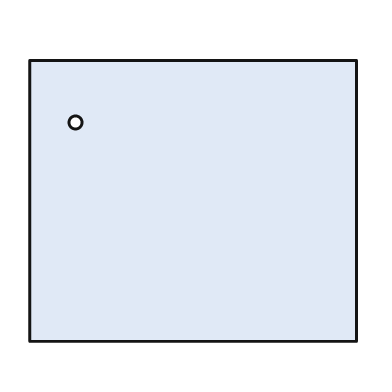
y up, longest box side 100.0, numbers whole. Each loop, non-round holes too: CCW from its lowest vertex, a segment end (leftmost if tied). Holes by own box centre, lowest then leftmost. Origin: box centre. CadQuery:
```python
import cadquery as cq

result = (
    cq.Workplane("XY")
    .moveTo(-50.0, -43.0)
    .lineTo(50.0, -43.0)
    .lineTo(50.0, 43.0)
    .lineTo(-50.0, 43.0)
    .close()
    .moveTo(-36.0, 24.0)
    .circle(2.0)
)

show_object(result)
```